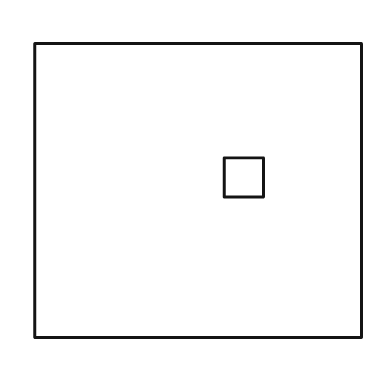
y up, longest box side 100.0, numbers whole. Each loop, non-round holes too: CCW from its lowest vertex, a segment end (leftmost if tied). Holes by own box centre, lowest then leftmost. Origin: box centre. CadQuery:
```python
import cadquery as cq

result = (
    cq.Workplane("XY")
    .moveTo(-50.0, -45.0)
    .lineTo(50.0, -45.0)
    .lineTo(50.0, 45.0)
    .lineTo(-50.0, 45.0)
    .close()
    .moveTo(8.0, -2.0)
    .lineTo(20.0, -2.0)
    .lineTo(20.0, 10.0)
    .lineTo(8.0, 10.0)
    .close()
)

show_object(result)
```